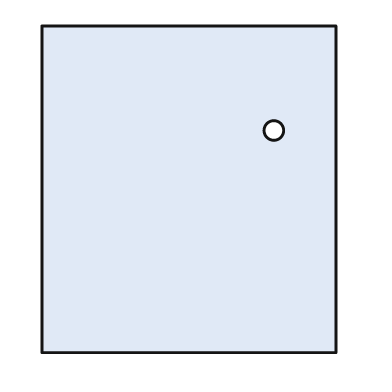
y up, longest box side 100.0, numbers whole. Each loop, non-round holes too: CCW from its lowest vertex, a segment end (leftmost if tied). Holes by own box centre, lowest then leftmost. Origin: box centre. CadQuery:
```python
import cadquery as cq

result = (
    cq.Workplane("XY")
    .moveTo(-45.0, -50.0)
    .lineTo(45.0, -50.0)
    .lineTo(45.0, 50.0)
    .lineTo(-45.0, 50.0)
    .close()
    .moveTo(26.0, 18.0)
    .circle(3.0)
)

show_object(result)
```